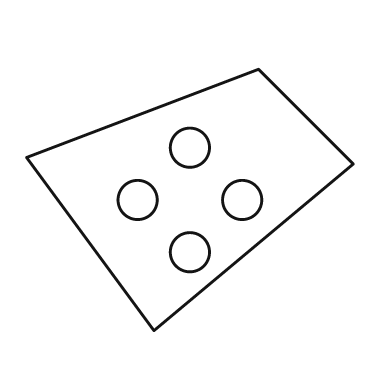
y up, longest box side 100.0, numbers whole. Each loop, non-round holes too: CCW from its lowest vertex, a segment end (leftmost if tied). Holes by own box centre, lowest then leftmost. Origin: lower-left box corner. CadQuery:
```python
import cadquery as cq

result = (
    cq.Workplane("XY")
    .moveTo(39.0, 0.0)
    .lineTo(100.0, 51.0)
    .lineTo(71.0, 80.0)
    .lineTo(0.0, 53.0)
    .close()
    .moveTo(50.0, 24.0)
    .circle(6.0)
    .moveTo(34.0, 40.0)
    .circle(6.0)
    .moveTo(66.0, 40.0)
    .circle(6.0)
    .moveTo(50.0, 56.0)
    .circle(6.0)
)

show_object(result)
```